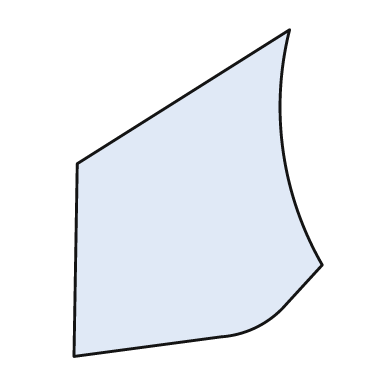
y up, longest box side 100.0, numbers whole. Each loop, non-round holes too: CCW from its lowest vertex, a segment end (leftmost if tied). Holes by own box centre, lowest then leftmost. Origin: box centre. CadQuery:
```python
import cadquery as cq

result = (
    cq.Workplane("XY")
    .moveTo(-38.0, -50.0)
    .lineTo(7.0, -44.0)
    .threePointArc((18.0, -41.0), (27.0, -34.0))
    .lineTo(38.0, -22.0)
    .threePointArc((26.0, 13.0), (28.0, 50.0))
    .lineTo(-37.0, 9.0)
    .close()
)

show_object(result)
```